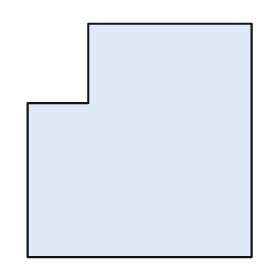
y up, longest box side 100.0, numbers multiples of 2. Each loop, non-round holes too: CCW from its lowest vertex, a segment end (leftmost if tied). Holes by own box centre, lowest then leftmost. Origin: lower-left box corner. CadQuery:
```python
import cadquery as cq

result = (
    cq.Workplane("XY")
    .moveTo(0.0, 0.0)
    .lineTo(96.0, 0.0)
    .lineTo(96.0, 100.0)
    .lineTo(26.0, 100.0)
    .lineTo(26.0, 66.0)
    .lineTo(0.0, 66.0)
    .close()
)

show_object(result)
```